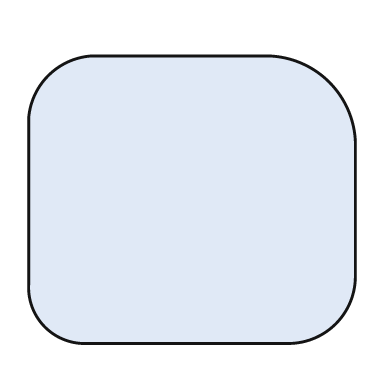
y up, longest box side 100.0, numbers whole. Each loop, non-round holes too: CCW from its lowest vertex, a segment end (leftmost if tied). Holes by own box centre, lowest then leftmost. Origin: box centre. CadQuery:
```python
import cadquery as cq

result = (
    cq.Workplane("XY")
    .moveTo(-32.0, -44.0)
    .lineTo(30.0, -44.0)
    .threePointArc((44.0, -38.0), (50.0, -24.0))
    .lineTo(50.0, 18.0)
    .threePointArc((42.0, 36.0), (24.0, 44.0))
    .lineTo(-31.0, 44.0)
    .threePointArc((-44.0, 38.0), (-50.0, 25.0))
    .lineTo(-50.0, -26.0)
    .threePointArc((-45.0, -39.0), (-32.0, -44.0))
    .close()
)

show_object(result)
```